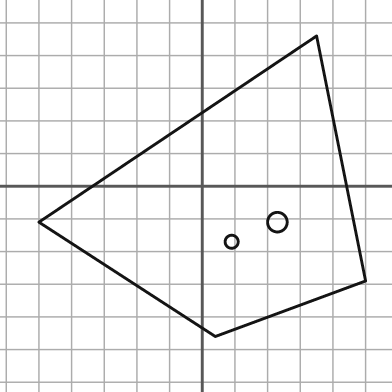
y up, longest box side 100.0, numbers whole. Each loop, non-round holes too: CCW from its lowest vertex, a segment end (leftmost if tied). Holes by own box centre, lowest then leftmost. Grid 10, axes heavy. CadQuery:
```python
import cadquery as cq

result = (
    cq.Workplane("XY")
    .moveTo(4.0, -46.0)
    .lineTo(50.0, -29.0)
    .lineTo(35.0, 46.0)
    .lineTo(-50.0, -11.0)
    .close()
    .moveTo(9.0, -17.0)
    .circle(2.0)
    .moveTo(23.0, -11.0)
    .circle(3.0)
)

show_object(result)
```